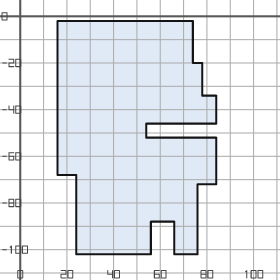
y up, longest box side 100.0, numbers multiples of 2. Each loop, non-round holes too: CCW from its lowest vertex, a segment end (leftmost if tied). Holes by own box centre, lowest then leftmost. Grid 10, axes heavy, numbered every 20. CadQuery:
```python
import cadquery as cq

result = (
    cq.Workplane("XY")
    .moveTo(24.0, -102.0)
    .lineTo(56.0, -102.0)
    .lineTo(56.0, -88.0)
    .lineTo(66.0, -88.0)
    .lineTo(66.0, -102.0)
    .lineTo(76.0, -102.0)
    .lineTo(76.0, -72.0)
    .lineTo(84.0, -72.0)
    .lineTo(84.0, -52.0)
    .lineTo(54.0, -52.0)
    .lineTo(54.0, -46.0)
    .lineTo(84.0, -46.0)
    .lineTo(84.0, -34.0)
    .lineTo(78.0, -34.0)
    .lineTo(78.0, -20.0)
    .lineTo(74.0, -20.0)
    .lineTo(74.0, -2.0)
    .lineTo(16.0, -2.0)
    .lineTo(16.0, -68.0)
    .lineTo(24.0, -68.0)
    .close()
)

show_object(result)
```